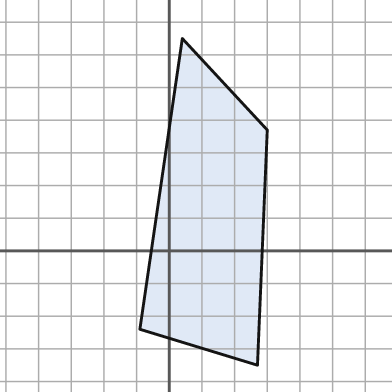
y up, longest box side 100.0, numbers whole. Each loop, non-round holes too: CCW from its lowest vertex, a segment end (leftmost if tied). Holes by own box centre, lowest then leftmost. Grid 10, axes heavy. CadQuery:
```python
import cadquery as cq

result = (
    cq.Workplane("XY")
    .moveTo(27.0, -35.0)
    .lineTo(30.0, 37.0)
    .lineTo(4.0, 65.0)
    .lineTo(-9.0, -24.0)
    .close()
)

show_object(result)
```